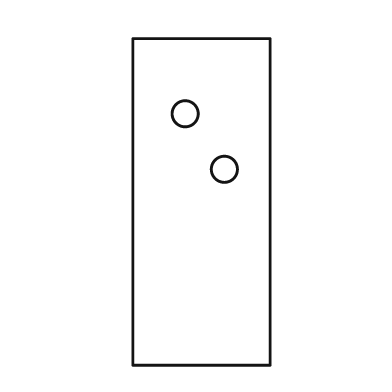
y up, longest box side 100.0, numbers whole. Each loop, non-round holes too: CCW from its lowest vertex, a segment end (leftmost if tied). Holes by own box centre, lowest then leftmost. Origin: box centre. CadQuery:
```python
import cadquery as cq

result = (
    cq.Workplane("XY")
    .moveTo(-21.0, -50.0)
    .lineTo(21.0, -50.0)
    .lineTo(21.0, 50.0)
    .lineTo(-21.0, 50.0)
    .close()
    .moveTo(7.0, 10.0)
    .circle(4.0)
    .moveTo(-5.0, 27.0)
    .circle(4.0)
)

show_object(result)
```